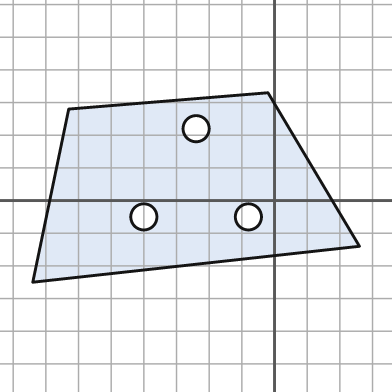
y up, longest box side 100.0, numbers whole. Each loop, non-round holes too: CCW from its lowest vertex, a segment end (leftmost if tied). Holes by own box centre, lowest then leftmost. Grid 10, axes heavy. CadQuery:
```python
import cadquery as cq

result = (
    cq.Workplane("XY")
    .moveTo(-74.0, -25.0)
    .lineTo(26.0, -14.0)
    .lineTo(-2.0, 33.0)
    .lineTo(-63.0, 28.0)
    .close()
    .moveTo(-40.0, -5.0)
    .circle(4.0)
    .moveTo(-8.0, -5.0)
    .circle(4.0)
    .moveTo(-24.0, 22.0)
    .circle(4.0)
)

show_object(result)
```